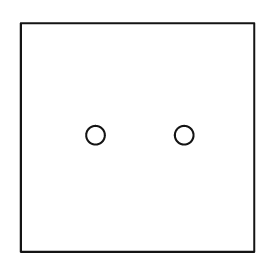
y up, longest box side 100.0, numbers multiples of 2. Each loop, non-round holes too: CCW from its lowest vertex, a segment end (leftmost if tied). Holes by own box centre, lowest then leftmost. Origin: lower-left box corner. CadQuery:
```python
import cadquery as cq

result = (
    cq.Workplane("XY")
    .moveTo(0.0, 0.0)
    .lineTo(100.0, 0.0)
    .lineTo(100.0, 98.0)
    .lineTo(0.0, 98.0)
    .close()
    .moveTo(32.0, 50.0)
    .circle(4.0)
    .moveTo(70.0, 50.0)
    .circle(4.0)
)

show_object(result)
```